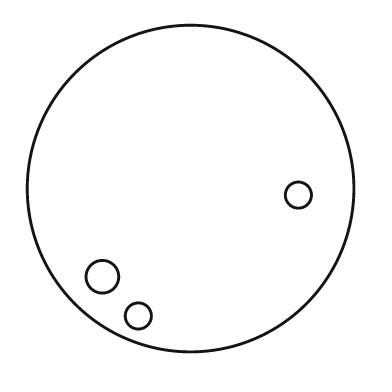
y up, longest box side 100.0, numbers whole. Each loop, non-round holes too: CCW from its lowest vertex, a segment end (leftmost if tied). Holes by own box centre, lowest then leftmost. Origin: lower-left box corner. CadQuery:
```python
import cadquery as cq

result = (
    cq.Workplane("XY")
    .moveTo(50.0, 50.0)
    .circle(50.0)
    .moveTo(34.0, 11.0)
    .circle(4.0)
    .moveTo(23.0, 23.0)
    .circle(5.0)
    .moveTo(83.0, 48.0)
    .circle(4.0)
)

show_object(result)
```